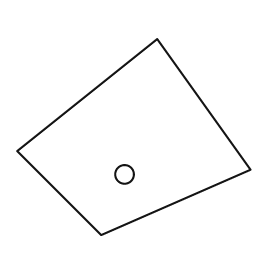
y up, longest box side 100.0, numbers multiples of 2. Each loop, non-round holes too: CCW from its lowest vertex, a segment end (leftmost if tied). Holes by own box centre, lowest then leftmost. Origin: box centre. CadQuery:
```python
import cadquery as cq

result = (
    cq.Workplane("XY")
    .moveTo(-14.0, -42.0)
    .lineTo(50.0, -14.0)
    .lineTo(10.0, 42.0)
    .lineTo(-50.0, -6.0)
    .close()
    .moveTo(-4.0, -16.0)
    .circle(4.0)
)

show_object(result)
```